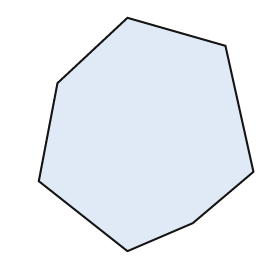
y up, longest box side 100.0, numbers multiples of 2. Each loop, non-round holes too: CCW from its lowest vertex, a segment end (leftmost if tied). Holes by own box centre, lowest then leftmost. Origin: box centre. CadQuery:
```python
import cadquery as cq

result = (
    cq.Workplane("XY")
    .moveTo(-8.0, -50.0)
    .lineTo(20.0, -38.0)
    .lineTo(46.0, -16.0)
    .lineTo(34.0, 38.0)
    .lineTo(-8.0, 50.0)
    .lineTo(-38.0, 22.0)
    .lineTo(-46.0, -20.0)
    .close()
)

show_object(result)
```